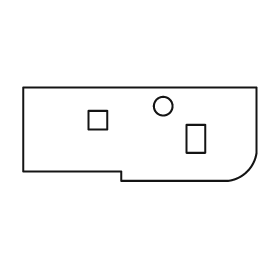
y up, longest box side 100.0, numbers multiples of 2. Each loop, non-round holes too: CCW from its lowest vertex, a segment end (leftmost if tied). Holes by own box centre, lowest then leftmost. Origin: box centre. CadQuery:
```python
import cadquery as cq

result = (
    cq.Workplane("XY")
    .moveTo(-8.0, -20.0)
    .lineTo(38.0, -20.0)
    .threePointArc((46.0, -16.0), (50.0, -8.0))
    .lineTo(50.0, 20.0)
    .lineTo(-50.0, 20.0)
    .lineTo(-50.0, -16.0)
    .lineTo(-8.0, -16.0)
    .close()
    .moveTo(20.0, -8.0)
    .lineTo(28.0, -8.0)
    .lineTo(28.0, 4.0)
    .lineTo(20.0, 4.0)
    .close()
    .moveTo(-22.0, 2.0)
    .lineTo(-14.0, 2.0)
    .lineTo(-14.0, 10.0)
    .lineTo(-22.0, 10.0)
    .close()
    .moveTo(10.0, 12.0)
    .circle(4.0)
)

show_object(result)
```